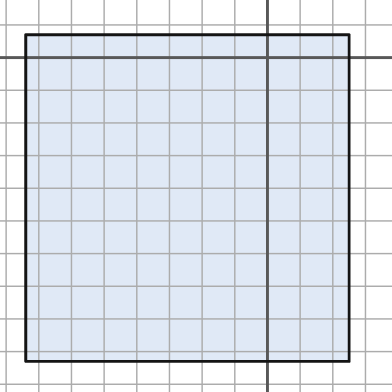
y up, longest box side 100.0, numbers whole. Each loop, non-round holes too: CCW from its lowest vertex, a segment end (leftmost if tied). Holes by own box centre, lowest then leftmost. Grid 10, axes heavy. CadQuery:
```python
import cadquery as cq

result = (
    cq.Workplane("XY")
    .moveTo(-74.0, -93.0)
    .lineTo(25.0, -93.0)
    .lineTo(25.0, 7.0)
    .lineTo(-74.0, 7.0)
    .close()
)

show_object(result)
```